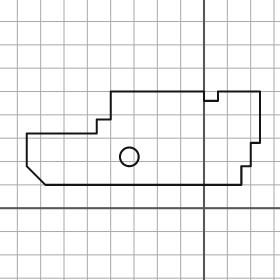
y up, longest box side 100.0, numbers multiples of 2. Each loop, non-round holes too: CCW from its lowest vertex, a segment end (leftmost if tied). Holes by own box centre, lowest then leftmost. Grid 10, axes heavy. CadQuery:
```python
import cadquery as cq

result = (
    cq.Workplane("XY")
    .moveTo(-68.0, 10.0)
    .lineTo(16.0, 10.0)
    .lineTo(16.0, 18.0)
    .lineTo(20.0, 18.0)
    .lineTo(20.0, 28.0)
    .lineTo(24.0, 28.0)
    .lineTo(24.0, 50.0)
    .lineTo(6.0, 50.0)
    .lineTo(6.0, 46.0)
    .lineTo(0.0, 46.0)
    .lineTo(0.0, 50.0)
    .lineTo(-40.0, 50.0)
    .lineTo(-40.0, 38.0)
    .lineTo(-46.0, 38.0)
    .lineTo(-46.0, 32.0)
    .lineTo(-76.0, 32.0)
    .lineTo(-76.0, 18.0)
    .close()
    .moveTo(-32.0, 22.0)
    .circle(4.0)
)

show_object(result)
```